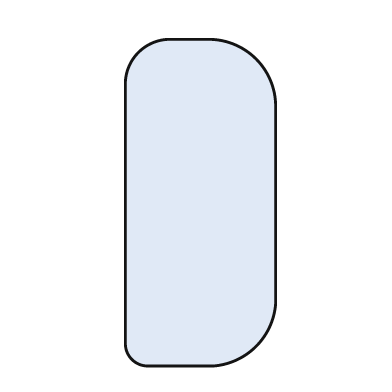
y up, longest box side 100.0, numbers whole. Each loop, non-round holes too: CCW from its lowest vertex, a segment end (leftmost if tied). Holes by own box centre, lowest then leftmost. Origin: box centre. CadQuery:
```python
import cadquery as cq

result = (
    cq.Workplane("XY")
    .moveTo(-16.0, -50.0)
    .lineTo(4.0, -50.0)
    .threePointArc((17.0, -44.0), (23.0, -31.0))
    .lineTo(23.0, 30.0)
    .threePointArc((17.0, 44.0), (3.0, 50.0))
    .lineTo(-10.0, 50.0)
    .threePointArc((-19.0, 46.0), (-23.0, 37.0))
    .lineTo(-23.0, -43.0)
    .threePointArc((-21.0, -48.0), (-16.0, -50.0))
    .close()
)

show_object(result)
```